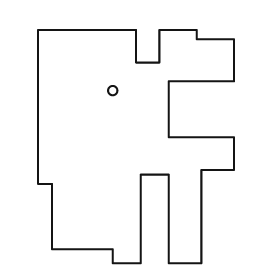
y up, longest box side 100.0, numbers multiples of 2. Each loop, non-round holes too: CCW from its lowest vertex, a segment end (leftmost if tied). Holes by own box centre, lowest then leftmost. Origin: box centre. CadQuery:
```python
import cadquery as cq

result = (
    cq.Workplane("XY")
    .moveTo(-10.0, -50.0)
    .lineTo(2.0, -50.0)
    .lineTo(2.0, -12.0)
    .lineTo(14.0, -12.0)
    .lineTo(14.0, -50.0)
    .lineTo(28.0, -50.0)
    .lineTo(28.0, -10.0)
    .lineTo(42.0, -10.0)
    .lineTo(42.0, 4.0)
    .lineTo(14.0, 4.0)
    .lineTo(14.0, 28.0)
    .lineTo(42.0, 28.0)
    .lineTo(42.0, 46.0)
    .lineTo(26.0, 46.0)
    .lineTo(26.0, 50.0)
    .lineTo(10.0, 50.0)
    .lineTo(10.0, 36.0)
    .lineTo(0.0, 36.0)
    .lineTo(0.0, 50.0)
    .lineTo(-42.0, 50.0)
    .lineTo(-42.0, -16.0)
    .lineTo(-36.0, -16.0)
    .lineTo(-36.0, -44.0)
    .lineTo(-10.0, -44.0)
    .close()
    .moveTo(-10.0, 24.0)
    .circle(2.0)
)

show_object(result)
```